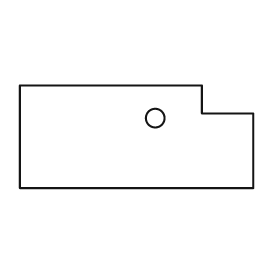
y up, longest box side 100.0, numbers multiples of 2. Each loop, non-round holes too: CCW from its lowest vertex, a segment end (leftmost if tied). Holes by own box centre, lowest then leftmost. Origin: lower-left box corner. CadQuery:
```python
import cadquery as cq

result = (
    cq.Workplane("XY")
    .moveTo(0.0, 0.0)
    .lineTo(100.0, 0.0)
    .lineTo(100.0, 32.0)
    .lineTo(78.0, 32.0)
    .lineTo(78.0, 44.0)
    .lineTo(0.0, 44.0)
    .close()
    .moveTo(58.0, 30.0)
    .circle(4.0)
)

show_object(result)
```